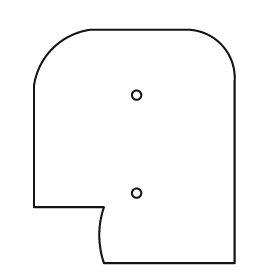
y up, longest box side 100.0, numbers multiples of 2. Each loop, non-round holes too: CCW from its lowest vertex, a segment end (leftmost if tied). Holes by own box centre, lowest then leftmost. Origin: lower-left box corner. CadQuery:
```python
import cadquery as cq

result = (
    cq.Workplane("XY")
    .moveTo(30.0, 0.0)
    .lineTo(86.0, 0.0)
    .lineTo(86.0, 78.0)
    .threePointArc((80.0, 94.0), (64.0, 100.0))
    .lineTo(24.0, 100.0)
    .threePointArc((8.0, 92.0), (0.0, 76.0))
    .lineTo(0.0, 24.0)
    .lineTo(30.0, 24.0)
    .threePointArc((28.0, 12.0), (30.0, 0.0))
    .close()
    .moveTo(44.0, 30.0)
    .circle(2.0)
    .moveTo(44.0, 72.0)
    .circle(2.0)
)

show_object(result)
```